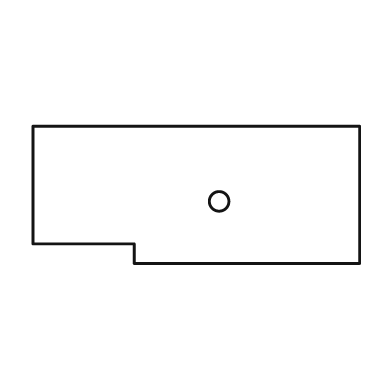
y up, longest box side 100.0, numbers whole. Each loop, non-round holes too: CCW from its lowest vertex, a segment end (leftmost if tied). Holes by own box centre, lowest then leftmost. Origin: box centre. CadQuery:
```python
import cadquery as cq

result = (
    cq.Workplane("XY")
    .moveTo(-19.0, -21.0)
    .lineTo(50.0, -21.0)
    .lineTo(50.0, 21.0)
    .lineTo(-50.0, 21.0)
    .lineTo(-50.0, -15.0)
    .lineTo(-19.0, -15.0)
    .close()
    .moveTo(7.0, -2.0)
    .circle(3.0)
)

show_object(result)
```